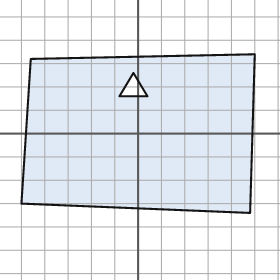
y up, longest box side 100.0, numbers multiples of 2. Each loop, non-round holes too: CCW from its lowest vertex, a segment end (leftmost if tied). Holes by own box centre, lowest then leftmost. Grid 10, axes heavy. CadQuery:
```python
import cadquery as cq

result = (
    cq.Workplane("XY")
    .moveTo(48.0, -34.0)
    .lineTo(50.0, 34.0)
    .lineTo(-46.0, 32.0)
    .lineTo(-50.0, -30.0)
    .close()
    .moveTo(-8.0, 16.0)
    .lineTo(4.0, 16.0)
    .lineTo(-2.0, 26.0)
    .close()
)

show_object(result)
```